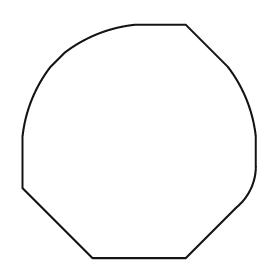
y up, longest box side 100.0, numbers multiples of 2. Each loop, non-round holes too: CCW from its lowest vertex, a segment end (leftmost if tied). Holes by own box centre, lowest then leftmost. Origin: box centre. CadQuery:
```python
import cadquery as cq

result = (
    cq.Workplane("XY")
    .moveTo(-20.0, -50.0)
    .lineTo(20.0, -50.0)
    .lineTo(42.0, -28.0)
    .threePointArc((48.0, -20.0), (50.0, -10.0))
    .lineTo(50.0, 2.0)
    .threePointArc((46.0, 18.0), (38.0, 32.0))
    .lineTo(20.0, 50.0)
    .lineTo(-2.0, 50.0)
    .threePointArc((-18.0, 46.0), (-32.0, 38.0))
    .lineTo(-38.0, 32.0)
    .threePointArc((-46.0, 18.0), (-50.0, 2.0))
    .lineTo(-50.0, -20.0)
    .close()
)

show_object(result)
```